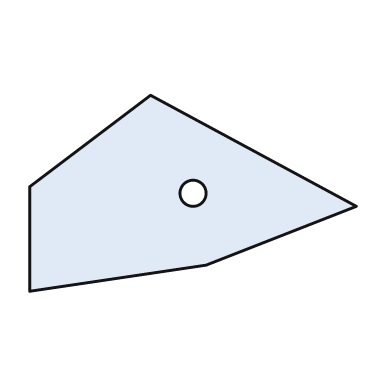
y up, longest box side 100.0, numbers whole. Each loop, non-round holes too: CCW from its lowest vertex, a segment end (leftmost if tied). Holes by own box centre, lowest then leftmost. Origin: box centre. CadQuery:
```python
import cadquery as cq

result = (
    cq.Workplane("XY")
    .moveTo(-50.0, -30.0)
    .lineTo(4.0, -22.0)
    .lineTo(50.0, -4.0)
    .lineTo(-13.0, 30.0)
    .lineTo(-50.0, 2.0)
    .close()
    .moveTo(0.0, 0.0)
    .circle(4.0)
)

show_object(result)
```